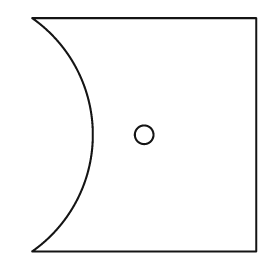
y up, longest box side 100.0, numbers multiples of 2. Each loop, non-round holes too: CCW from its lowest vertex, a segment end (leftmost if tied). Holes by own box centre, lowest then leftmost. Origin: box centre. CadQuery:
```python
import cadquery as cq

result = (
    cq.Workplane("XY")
    .moveTo(-48.0, -50.0)
    .lineTo(48.0, -50.0)
    .lineTo(48.0, 50.0)
    .lineTo(-48.0, 50.0)
    .threePointArc((-22.0, 0.0), (-48.0, -50.0))
    .close()
    .moveTo(0.0, 0.0)
    .circle(4.0)
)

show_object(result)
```